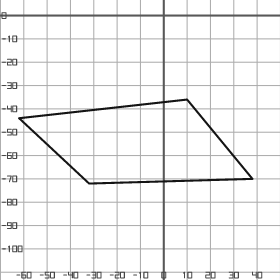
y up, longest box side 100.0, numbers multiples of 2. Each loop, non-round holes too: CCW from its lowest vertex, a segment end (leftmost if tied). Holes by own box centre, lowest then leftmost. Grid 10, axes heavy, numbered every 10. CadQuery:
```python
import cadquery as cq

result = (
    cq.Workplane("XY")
    .moveTo(-32.0, -72.0)
    .lineTo(38.0, -70.0)
    .lineTo(10.0, -36.0)
    .lineTo(-62.0, -44.0)
    .close()
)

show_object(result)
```